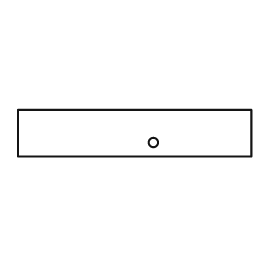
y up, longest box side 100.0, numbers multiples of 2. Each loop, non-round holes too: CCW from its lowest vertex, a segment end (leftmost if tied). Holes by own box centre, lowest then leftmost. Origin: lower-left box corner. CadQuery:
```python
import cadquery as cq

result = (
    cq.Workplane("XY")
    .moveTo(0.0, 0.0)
    .lineTo(100.0, 0.0)
    .lineTo(100.0, 20.0)
    .lineTo(0.0, 20.0)
    .close()
    .moveTo(58.0, 6.0)
    .circle(2.0)
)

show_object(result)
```